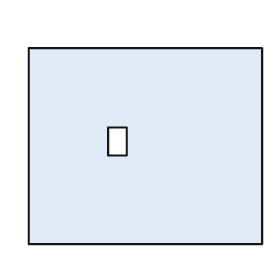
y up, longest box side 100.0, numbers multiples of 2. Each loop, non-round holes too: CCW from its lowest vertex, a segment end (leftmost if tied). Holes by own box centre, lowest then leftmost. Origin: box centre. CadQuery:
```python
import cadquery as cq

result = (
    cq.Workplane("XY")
    .moveTo(-50.0, -42.0)
    .lineTo(50.0, -42.0)
    .lineTo(50.0, 42.0)
    .lineTo(-50.0, 42.0)
    .close()
    .moveTo(-16.0, -4.0)
    .lineTo(-8.0, -4.0)
    .lineTo(-8.0, 8.0)
    .lineTo(-16.0, 8.0)
    .close()
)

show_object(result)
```